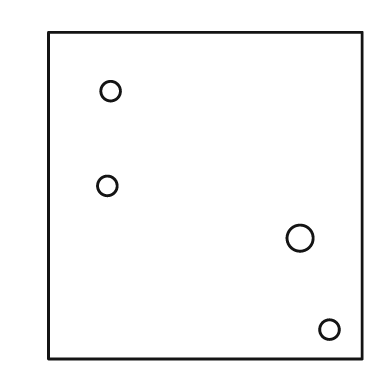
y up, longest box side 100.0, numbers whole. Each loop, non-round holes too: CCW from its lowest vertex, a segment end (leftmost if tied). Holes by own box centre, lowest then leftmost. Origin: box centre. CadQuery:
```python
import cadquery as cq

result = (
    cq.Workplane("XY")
    .moveTo(-48.0, -50.0)
    .lineTo(48.0, -50.0)
    .lineTo(48.0, 50.0)
    .lineTo(-48.0, 50.0)
    .close()
    .moveTo(38.0, -41.0)
    .circle(3.0)
    .moveTo(29.0, -13.0)
    .circle(4.0)
    .moveTo(-30.0, 3.0)
    .circle(3.0)
    .moveTo(-29.0, 32.0)
    .circle(3.0)
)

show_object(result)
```